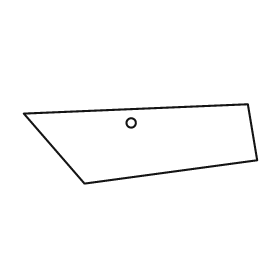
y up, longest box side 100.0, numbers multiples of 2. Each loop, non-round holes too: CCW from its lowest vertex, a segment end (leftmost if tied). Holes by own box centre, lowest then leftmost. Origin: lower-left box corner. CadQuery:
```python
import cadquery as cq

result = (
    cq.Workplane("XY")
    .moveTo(26.0, 0.0)
    .lineTo(100.0, 10.0)
    .lineTo(96.0, 34.0)
    .lineTo(0.0, 30.0)
    .close()
    .moveTo(46.0, 26.0)
    .circle(2.0)
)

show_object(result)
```